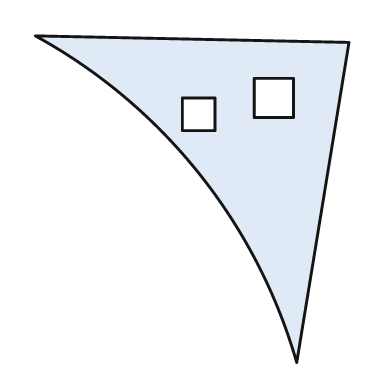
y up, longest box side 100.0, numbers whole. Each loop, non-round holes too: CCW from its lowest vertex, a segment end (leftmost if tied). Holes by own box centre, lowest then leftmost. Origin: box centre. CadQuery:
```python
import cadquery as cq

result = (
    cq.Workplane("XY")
    .moveTo(32.0, -50.0)
    .lineTo(48.0, 48.0)
    .lineTo(-48.0, 50.0)
    .threePointArc((2.0, 8.0), (32.0, -50.0))
    .close()
    .moveTo(-3.0, 21.0)
    .lineTo(7.0, 21.0)
    .lineTo(7.0, 31.0)
    .lineTo(-3.0, 31.0)
    .close()
    .moveTo(19.0, 25.0)
    .lineTo(31.0, 25.0)
    .lineTo(31.0, 37.0)
    .lineTo(19.0, 37.0)
    .close()
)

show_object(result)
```